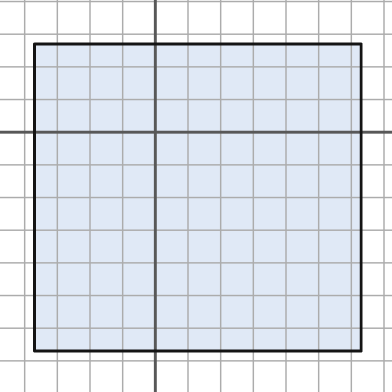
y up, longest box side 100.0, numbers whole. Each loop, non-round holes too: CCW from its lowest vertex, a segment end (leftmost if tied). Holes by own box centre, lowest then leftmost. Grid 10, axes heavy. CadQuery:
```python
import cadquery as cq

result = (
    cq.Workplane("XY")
    .moveTo(-37.0, -67.0)
    .lineTo(63.0, -67.0)
    .lineTo(63.0, 27.0)
    .lineTo(-37.0, 27.0)
    .close()
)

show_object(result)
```